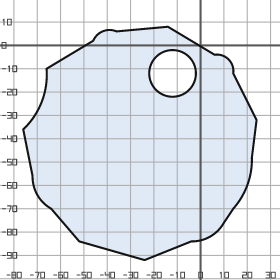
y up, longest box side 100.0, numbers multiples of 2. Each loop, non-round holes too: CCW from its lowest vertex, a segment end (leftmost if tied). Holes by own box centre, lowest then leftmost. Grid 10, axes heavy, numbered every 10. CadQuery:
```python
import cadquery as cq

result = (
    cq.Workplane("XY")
    .moveTo(-24.0, -92.0)
    .lineTo(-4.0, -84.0)
    .threePointArc((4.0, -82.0), (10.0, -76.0))
    .lineTo(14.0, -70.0)
    .threePointArc((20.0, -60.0), (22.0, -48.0))
    .lineTo(24.0, -32.0)
    .lineTo(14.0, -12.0)
    .threePointArc((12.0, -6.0), (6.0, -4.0))
    .lineTo(-14.0, 8.0)
    .lineTo(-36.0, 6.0)
    .threePointArc((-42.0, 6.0), (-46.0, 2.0))
    .lineTo(-66.0, -10.0)
    .threePointArc((-68.0, -24.0), (-76.0, -36.0))
    .lineTo(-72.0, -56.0)
    .threePointArc((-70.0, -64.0), (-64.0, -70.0))
    .lineTo(-52.0, -84.0)
    .close()
    .moveTo(-12.0, -12.0)
    .circle(10.0)
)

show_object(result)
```